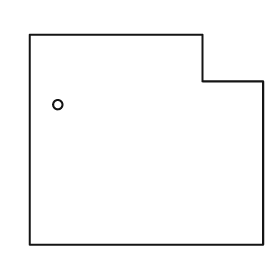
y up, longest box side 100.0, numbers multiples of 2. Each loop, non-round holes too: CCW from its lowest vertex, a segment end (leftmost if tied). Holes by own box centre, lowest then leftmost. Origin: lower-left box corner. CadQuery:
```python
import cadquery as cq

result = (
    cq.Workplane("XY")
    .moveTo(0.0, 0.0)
    .lineTo(100.0, 0.0)
    .lineTo(100.0, 70.0)
    .lineTo(74.0, 70.0)
    .lineTo(74.0, 90.0)
    .lineTo(0.0, 90.0)
    .close()
    .moveTo(12.0, 60.0)
    .circle(2.0)
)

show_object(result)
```